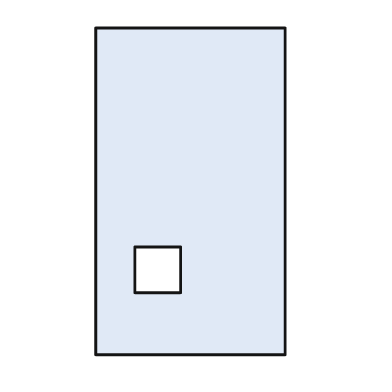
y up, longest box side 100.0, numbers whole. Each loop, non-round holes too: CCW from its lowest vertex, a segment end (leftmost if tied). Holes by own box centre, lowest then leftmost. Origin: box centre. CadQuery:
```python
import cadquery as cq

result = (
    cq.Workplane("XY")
    .moveTo(-29.0, -50.0)
    .lineTo(29.0, -50.0)
    .lineTo(29.0, 50.0)
    .lineTo(-29.0, 50.0)
    .close()
    .moveTo(-17.0, -31.0)
    .lineTo(-3.0, -31.0)
    .lineTo(-3.0, -17.0)
    .lineTo(-17.0, -17.0)
    .close()
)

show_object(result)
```